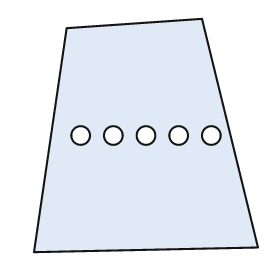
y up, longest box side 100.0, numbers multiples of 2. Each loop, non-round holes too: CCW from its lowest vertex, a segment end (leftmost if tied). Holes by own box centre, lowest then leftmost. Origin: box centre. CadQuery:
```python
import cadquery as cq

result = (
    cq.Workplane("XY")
    .moveTo(-48.0, -50.0)
    .lineTo(48.0, -48.0)
    .lineTo(24.0, 50.0)
    .lineTo(-34.0, 46.0)
    .close()
    .moveTo(-28.0, 0.0)
    .circle(4.0)
    .moveTo(-14.0, 0.0)
    .circle(4.0)
    .moveTo(0.0, 0.0)
    .circle(4.0)
    .moveTo(14.0, 0.0)
    .circle(4.0)
    .moveTo(28.0, 0.0)
    .circle(4.0)
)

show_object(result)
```